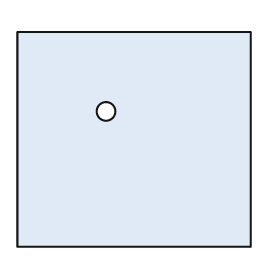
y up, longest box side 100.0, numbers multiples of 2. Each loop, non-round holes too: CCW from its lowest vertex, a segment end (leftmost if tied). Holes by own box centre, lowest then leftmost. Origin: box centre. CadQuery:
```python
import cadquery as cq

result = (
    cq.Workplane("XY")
    .moveTo(-50.0, -46.0)
    .lineTo(50.0, -46.0)
    .lineTo(50.0, 46.0)
    .lineTo(-50.0, 46.0)
    .close()
    .moveTo(-12.0, 12.0)
    .circle(4.0)
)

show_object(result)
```